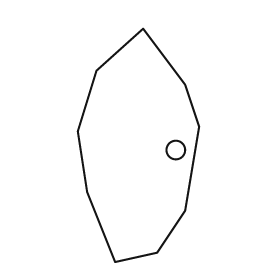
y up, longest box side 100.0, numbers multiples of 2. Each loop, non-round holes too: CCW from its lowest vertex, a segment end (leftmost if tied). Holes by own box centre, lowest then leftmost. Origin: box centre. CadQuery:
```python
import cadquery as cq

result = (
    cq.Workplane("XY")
    .moveTo(-10.0, -50.0)
    .lineTo(8.0, -46.0)
    .lineTo(20.0, -28.0)
    .lineTo(26.0, 8.0)
    .lineTo(20.0, 26.0)
    .lineTo(2.0, 50.0)
    .lineTo(-18.0, 32.0)
    .lineTo(-26.0, 6.0)
    .lineTo(-22.0, -20.0)
    .close()
    .moveTo(16.0, -2.0)
    .circle(4.0)
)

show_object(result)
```